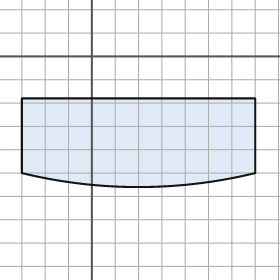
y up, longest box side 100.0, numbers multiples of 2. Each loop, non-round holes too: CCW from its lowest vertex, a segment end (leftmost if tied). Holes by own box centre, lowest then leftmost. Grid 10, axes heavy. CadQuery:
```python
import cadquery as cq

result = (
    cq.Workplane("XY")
    .moveTo(-30.0, -50.0)
    .threePointArc((20.0, -56.0), (70.0, -50.0))
    .lineTo(70.0, -18.0)
    .lineTo(-30.0, -18.0)
    .close()
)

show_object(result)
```